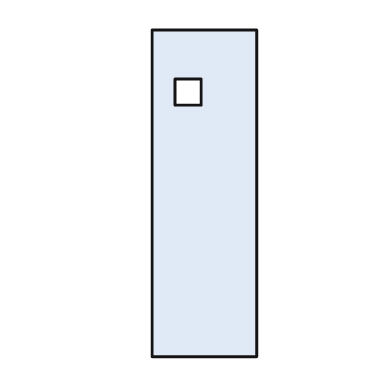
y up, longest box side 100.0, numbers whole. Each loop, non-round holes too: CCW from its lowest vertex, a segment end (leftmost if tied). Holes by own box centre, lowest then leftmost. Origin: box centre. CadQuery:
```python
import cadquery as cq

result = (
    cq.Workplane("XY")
    .moveTo(-16.0, -50.0)
    .lineTo(16.0, -50.0)
    .lineTo(16.0, 50.0)
    .lineTo(-16.0, 50.0)
    .close()
    .moveTo(-9.0, 27.0)
    .lineTo(-1.0, 27.0)
    .lineTo(-1.0, 35.0)
    .lineTo(-9.0, 35.0)
    .close()
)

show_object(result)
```